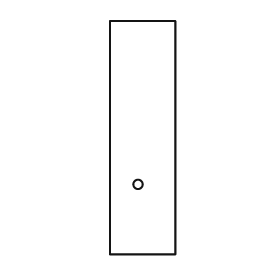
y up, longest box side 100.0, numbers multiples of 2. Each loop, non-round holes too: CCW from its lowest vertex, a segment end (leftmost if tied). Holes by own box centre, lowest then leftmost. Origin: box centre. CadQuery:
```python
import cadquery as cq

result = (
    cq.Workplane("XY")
    .moveTo(-14.0, -50.0)
    .lineTo(14.0, -50.0)
    .lineTo(14.0, 50.0)
    .lineTo(-14.0, 50.0)
    .close()
    .moveTo(-2.0, -20.0)
    .circle(2.0)
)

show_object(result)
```